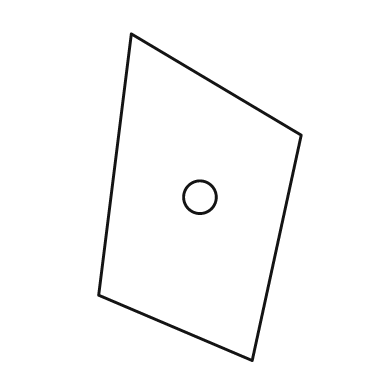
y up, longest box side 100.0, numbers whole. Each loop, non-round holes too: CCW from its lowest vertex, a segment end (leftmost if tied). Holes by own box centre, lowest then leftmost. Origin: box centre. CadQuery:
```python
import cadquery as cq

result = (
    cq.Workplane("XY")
    .moveTo(16.0, -50.0)
    .lineTo(31.0, 19.0)
    .lineTo(-21.0, 50.0)
    .lineTo(-31.0, -30.0)
    .close()
    .moveTo(0.0, 0.0)
    .circle(5.0)
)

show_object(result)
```